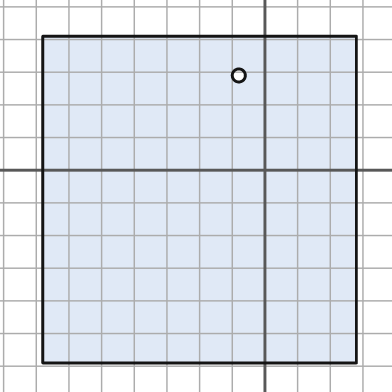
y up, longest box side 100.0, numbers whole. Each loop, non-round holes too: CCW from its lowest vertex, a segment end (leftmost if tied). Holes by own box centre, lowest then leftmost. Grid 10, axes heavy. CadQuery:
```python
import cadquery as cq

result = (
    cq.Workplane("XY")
    .moveTo(-68.0, -59.0)
    .lineTo(28.0, -59.0)
    .lineTo(28.0, 41.0)
    .lineTo(-68.0, 41.0)
    .close()
    .moveTo(-8.0, 29.0)
    .circle(2.0)
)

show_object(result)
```